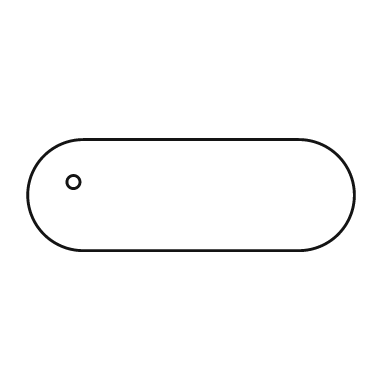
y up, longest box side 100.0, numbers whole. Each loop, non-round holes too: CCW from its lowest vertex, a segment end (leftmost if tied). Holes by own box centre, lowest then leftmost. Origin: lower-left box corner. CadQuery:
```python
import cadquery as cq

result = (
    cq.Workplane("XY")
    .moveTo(17.0, 0.0)
    .lineTo(83.0, 0.0)
    .threePointArc((100.0, 17.0), (83.0, 34.0))
    .lineTo(17.0, 34.0)
    .threePointArc((0.0, 17.0), (17.0, 0.0))
    .close()
    .moveTo(14.0, 21.0)
    .circle(2.0)
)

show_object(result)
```